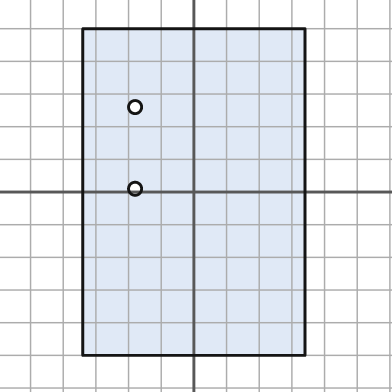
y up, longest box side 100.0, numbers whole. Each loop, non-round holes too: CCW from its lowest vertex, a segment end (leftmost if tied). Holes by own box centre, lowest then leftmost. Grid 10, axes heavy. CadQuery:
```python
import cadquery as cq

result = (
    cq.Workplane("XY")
    .moveTo(-34.0, -50.0)
    .lineTo(34.0, -50.0)
    .lineTo(34.0, 50.0)
    .lineTo(-34.0, 50.0)
    .close()
    .moveTo(-18.0, 1.0)
    .circle(2.0)
    .moveTo(-18.0, 26.0)
    .circle(2.0)
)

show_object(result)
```